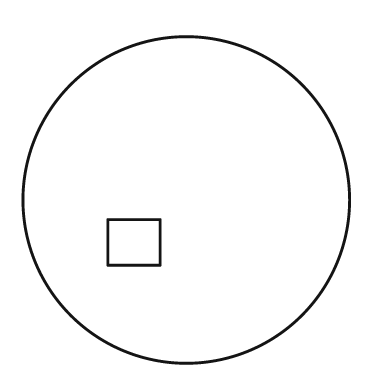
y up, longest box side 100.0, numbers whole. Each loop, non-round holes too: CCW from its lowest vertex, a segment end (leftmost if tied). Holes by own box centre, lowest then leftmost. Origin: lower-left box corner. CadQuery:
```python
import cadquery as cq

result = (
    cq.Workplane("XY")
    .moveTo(50.0, 50.0)
    .circle(50.0)
    .moveTo(26.0, 30.0)
    .lineTo(42.0, 30.0)
    .lineTo(42.0, 44.0)
    .lineTo(26.0, 44.0)
    .close()
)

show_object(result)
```